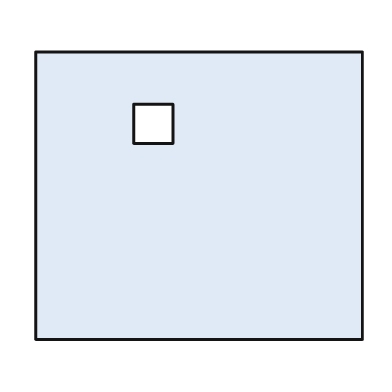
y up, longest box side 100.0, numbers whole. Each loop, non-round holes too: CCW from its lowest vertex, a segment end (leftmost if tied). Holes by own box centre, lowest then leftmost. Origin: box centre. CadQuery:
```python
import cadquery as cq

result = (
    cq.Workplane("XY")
    .moveTo(-50.0, -44.0)
    .lineTo(50.0, -44.0)
    .lineTo(50.0, 44.0)
    .lineTo(-50.0, 44.0)
    .close()
    .moveTo(-20.0, 16.0)
    .lineTo(-8.0, 16.0)
    .lineTo(-8.0, 28.0)
    .lineTo(-20.0, 28.0)
    .close()
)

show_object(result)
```